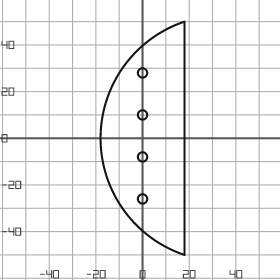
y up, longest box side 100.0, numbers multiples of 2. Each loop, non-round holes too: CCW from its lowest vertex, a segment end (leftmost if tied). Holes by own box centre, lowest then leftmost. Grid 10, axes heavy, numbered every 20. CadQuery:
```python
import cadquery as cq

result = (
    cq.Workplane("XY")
    .moveTo(18.0, -50.0)
    .lineTo(18.0, 50.0)
    .threePointArc((-18.0, 0.0), (18.0, -50.0))
    .close()
    .moveTo(0.0, -26.0)
    .circle(2.0)
    .moveTo(0.0, -8.0)
    .circle(2.0)
    .moveTo(0.0, 10.0)
    .circle(2.0)
    .moveTo(0.0, 28.0)
    .circle(2.0)
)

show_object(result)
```